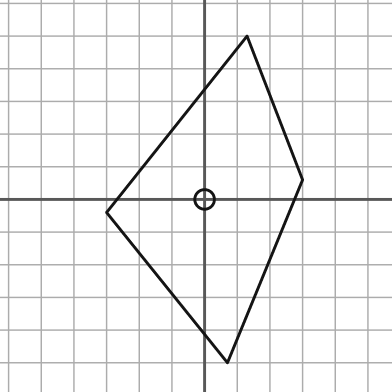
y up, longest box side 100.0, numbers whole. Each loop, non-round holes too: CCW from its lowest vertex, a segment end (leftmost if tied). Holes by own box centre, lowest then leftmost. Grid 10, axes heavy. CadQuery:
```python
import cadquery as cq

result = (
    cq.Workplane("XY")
    .moveTo(7.0, -50.0)
    .lineTo(30.0, 6.0)
    .lineTo(13.0, 50.0)
    .lineTo(-30.0, -4.0)
    .close()
    .moveTo(0.0, 0.0)
    .circle(3.0)
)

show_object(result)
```